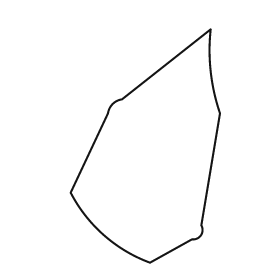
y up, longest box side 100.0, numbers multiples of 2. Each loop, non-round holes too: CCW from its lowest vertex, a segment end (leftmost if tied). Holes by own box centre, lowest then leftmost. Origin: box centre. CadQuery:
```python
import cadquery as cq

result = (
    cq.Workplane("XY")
    .moveTo(2.0, -50.0)
    .lineTo(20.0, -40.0)
    .threePointArc((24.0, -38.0), (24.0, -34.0))
    .lineTo(32.0, 14.0)
    .threePointArc((28.0, 32.0), (28.0, 50.0))
    .lineTo(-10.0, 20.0)
    .threePointArc((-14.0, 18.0), (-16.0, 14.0))
    .lineTo(-32.0, -20.0)
    .threePointArc((-18.0, -38.0), (2.0, -50.0))
    .close()
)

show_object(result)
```